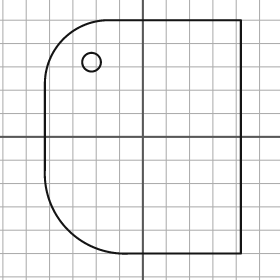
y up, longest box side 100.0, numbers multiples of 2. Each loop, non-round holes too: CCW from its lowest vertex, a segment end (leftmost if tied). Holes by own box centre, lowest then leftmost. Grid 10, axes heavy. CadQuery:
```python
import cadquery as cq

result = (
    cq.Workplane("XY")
    .moveTo(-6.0, -50.0)
    .lineTo(42.0, -50.0)
    .lineTo(42.0, 50.0)
    .lineTo(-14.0, 50.0)
    .threePointArc((-34.0, 42.0), (-42.0, 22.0))
    .lineTo(-42.0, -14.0)
    .threePointArc((-32.0, -40.0), (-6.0, -50.0))
    .close()
    .moveTo(-22.0, 32.0)
    .circle(4.0)
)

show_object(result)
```